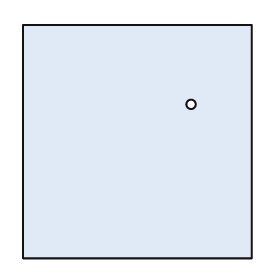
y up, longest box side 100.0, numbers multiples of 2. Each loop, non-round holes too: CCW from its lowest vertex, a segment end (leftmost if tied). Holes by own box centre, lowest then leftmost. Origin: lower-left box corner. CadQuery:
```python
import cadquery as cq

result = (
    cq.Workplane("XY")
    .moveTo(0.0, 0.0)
    .lineTo(98.0, 0.0)
    .lineTo(98.0, 100.0)
    .lineTo(0.0, 100.0)
    .close()
    .moveTo(72.0, 66.0)
    .circle(2.0)
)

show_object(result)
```